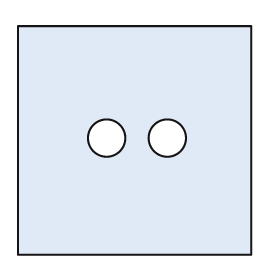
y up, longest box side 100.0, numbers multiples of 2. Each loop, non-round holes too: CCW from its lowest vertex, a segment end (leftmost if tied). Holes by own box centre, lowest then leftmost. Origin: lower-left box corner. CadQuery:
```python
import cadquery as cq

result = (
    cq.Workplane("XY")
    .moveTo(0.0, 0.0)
    .lineTo(100.0, 0.0)
    .lineTo(100.0, 98.0)
    .lineTo(0.0, 98.0)
    .close()
    .moveTo(38.0, 50.0)
    .circle(8.0)
    .moveTo(64.0, 50.0)
    .circle(8.0)
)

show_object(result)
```